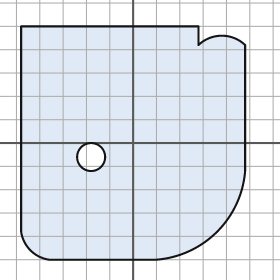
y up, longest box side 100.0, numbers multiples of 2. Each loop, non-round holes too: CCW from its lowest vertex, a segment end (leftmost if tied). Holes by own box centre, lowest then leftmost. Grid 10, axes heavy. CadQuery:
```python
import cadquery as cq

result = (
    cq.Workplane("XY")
    .moveTo(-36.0, -50.0)
    .lineTo(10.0, -50.0)
    .threePointArc((36.0, -38.0), (48.0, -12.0))
    .lineTo(48.0, 42.0)
    .threePointArc((38.0, 46.0), (28.0, 42.0))
    .lineTo(28.0, 50.0)
    .lineTo(-48.0, 50.0)
    .lineTo(-48.0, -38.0)
    .threePointArc((-44.0, -46.0), (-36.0, -50.0))
    .close()
    .moveTo(-18.0, -6.0)
    .circle(6.0)
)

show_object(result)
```